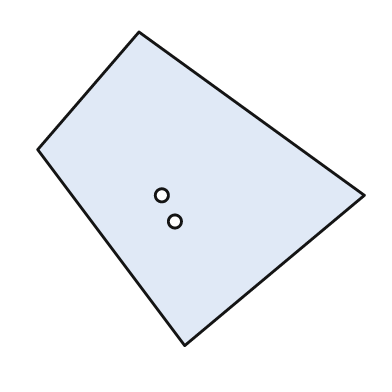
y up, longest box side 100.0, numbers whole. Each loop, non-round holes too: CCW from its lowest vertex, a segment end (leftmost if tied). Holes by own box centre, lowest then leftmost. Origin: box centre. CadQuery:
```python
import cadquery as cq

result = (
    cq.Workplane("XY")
    .moveTo(-5.0, -48.0)
    .lineTo(50.0, -2.0)
    .lineTo(-19.0, 48.0)
    .lineTo(-50.0, 12.0)
    .close()
    .moveTo(-8.0, -10.0)
    .circle(2.0)
    .moveTo(-12.0, -2.0)
    .circle(2.0)
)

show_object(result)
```